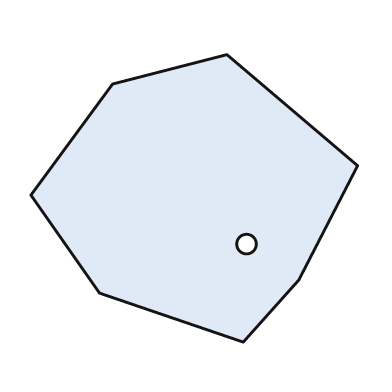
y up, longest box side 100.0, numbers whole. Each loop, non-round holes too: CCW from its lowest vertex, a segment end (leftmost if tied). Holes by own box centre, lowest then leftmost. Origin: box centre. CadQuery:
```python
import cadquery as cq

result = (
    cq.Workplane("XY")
    .moveTo(15.0, -44.0)
    .lineTo(32.0, -25.0)
    .lineTo(50.0, 10.0)
    .lineTo(10.0, 44.0)
    .lineTo(-25.0, 35.0)
    .lineTo(-50.0, 1.0)
    .lineTo(-29.0, -29.0)
    .close()
    .moveTo(16.0, -14.0)
    .circle(3.0)
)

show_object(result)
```